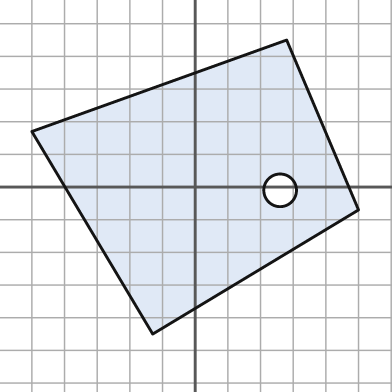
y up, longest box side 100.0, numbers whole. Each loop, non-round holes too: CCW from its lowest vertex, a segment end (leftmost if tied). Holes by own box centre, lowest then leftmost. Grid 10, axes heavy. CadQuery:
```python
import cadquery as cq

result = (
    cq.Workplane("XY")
    .moveTo(-13.0, -45.0)
    .lineTo(50.0, -7.0)
    .lineTo(28.0, 45.0)
    .lineTo(-50.0, 17.0)
    .close()
    .moveTo(26.0, -1.0)
    .circle(5.0)
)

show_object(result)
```